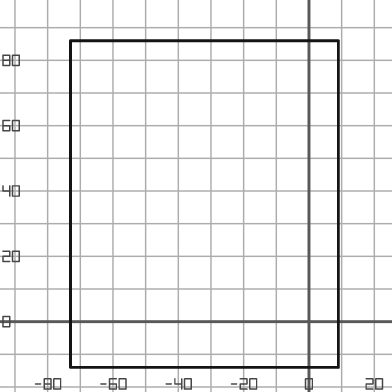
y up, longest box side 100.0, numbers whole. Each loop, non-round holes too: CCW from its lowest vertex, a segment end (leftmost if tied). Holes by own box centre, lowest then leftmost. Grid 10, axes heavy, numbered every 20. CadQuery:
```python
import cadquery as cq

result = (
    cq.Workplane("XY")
    .moveTo(-73.0, -14.0)
    .lineTo(9.0, -14.0)
    .lineTo(9.0, 86.0)
    .lineTo(-73.0, 86.0)
    .close()
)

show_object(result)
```